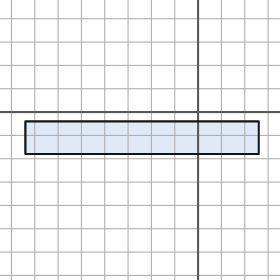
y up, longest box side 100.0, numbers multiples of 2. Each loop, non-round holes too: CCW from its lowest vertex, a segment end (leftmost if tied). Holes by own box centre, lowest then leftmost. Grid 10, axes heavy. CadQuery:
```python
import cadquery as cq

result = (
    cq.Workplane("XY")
    .moveTo(-74.0, -18.0)
    .lineTo(26.0, -18.0)
    .lineTo(26.0, -4.0)
    .lineTo(-74.0, -4.0)
    .close()
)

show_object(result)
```